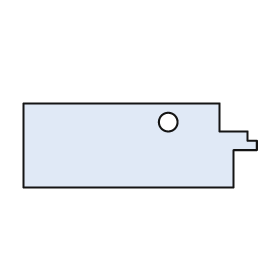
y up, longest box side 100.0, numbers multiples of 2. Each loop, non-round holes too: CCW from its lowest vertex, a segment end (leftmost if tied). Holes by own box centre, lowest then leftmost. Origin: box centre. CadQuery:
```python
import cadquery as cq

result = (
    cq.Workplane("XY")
    .moveTo(-50.0, -18.0)
    .lineTo(40.0, -18.0)
    .lineTo(40.0, -2.0)
    .lineTo(50.0, -2.0)
    .lineTo(50.0, 2.0)
    .lineTo(46.0, 2.0)
    .lineTo(46.0, 6.0)
    .lineTo(34.0, 6.0)
    .lineTo(34.0, 18.0)
    .lineTo(-50.0, 18.0)
    .close()
    .moveTo(12.0, 10.0)
    .circle(4.0)
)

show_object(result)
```